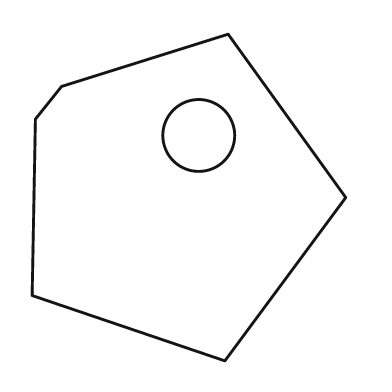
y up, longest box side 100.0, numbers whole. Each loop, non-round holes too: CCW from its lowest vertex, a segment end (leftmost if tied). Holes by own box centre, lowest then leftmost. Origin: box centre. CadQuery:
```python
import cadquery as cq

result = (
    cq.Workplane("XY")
    .moveTo(11.0, -50.0)
    .lineTo(48.0, 0.0)
    .lineTo(12.0, 50.0)
    .lineTo(-39.0, 34.0)
    .lineTo(-47.0, 24.0)
    .lineTo(-48.0, -30.0)
    .close()
    .moveTo(3.0, 19.0)
    .circle(11.0)
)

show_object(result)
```